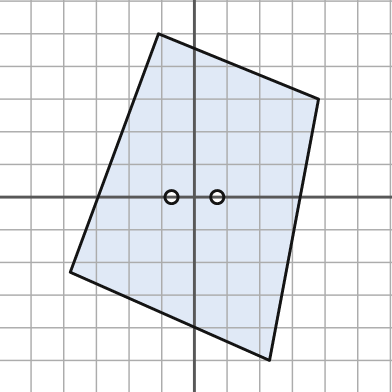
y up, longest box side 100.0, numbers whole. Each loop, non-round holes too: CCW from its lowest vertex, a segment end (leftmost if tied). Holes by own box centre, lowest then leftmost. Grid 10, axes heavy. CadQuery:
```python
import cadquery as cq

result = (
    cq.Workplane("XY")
    .moveTo(23.0, -50.0)
    .lineTo(38.0, 30.0)
    .lineTo(-11.0, 50.0)
    .lineTo(-38.0, -23.0)
    .close()
    .moveTo(-7.0, 0.0)
    .circle(2.0)
    .moveTo(7.0, 0.0)
    .circle(2.0)
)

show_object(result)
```